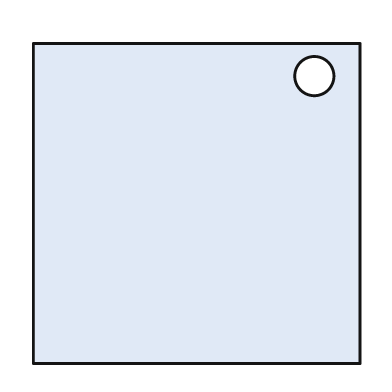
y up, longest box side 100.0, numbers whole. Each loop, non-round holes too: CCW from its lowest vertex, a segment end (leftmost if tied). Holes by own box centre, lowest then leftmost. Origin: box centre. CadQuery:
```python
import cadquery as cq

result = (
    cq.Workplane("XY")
    .moveTo(-50.0, -49.0)
    .lineTo(50.0, -49.0)
    .lineTo(50.0, 49.0)
    .lineTo(-50.0, 49.0)
    .close()
    .moveTo(36.0, 39.0)
    .circle(6.0)
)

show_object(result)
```